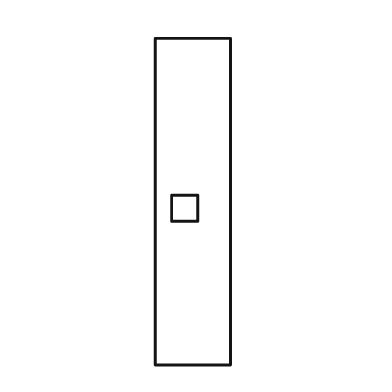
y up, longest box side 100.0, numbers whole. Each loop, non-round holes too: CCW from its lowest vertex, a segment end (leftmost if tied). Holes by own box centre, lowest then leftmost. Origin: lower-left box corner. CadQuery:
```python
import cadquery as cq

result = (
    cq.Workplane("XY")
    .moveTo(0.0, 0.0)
    .lineTo(23.0, 0.0)
    .lineTo(23.0, 100.0)
    .lineTo(0.0, 100.0)
    .close()
    .moveTo(5.0, 44.0)
    .lineTo(13.0, 44.0)
    .lineTo(13.0, 52.0)
    .lineTo(5.0, 52.0)
    .close()
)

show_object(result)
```